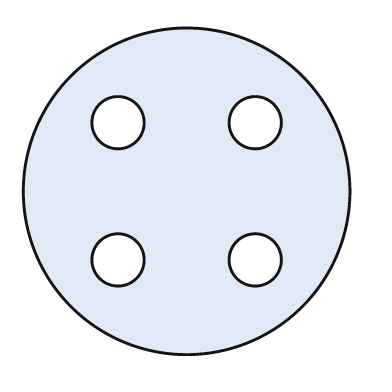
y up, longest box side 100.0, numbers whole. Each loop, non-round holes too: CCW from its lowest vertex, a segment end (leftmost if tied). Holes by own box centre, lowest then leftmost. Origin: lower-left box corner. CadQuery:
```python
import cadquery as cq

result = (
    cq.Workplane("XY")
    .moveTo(50.0, 50.0)
    .circle(50.0)
    .moveTo(29.0, 29.0)
    .circle(8.0)
    .moveTo(71.0, 29.0)
    .circle(8.0)
    .moveTo(29.0, 71.0)
    .circle(8.0)
    .moveTo(71.0, 71.0)
    .circle(8.0)
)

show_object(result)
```